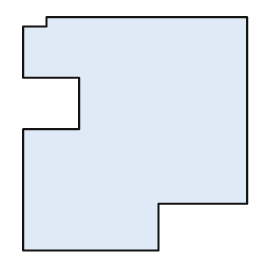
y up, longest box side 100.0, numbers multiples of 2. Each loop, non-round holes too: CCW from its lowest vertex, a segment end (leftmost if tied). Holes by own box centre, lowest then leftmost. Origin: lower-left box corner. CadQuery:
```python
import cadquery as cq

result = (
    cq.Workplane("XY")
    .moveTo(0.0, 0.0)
    .lineTo(58.0, 0.0)
    .lineTo(58.0, 20.0)
    .lineTo(96.0, 20.0)
    .lineTo(96.0, 100.0)
    .lineTo(10.0, 100.0)
    .lineTo(10.0, 96.0)
    .lineTo(0.0, 96.0)
    .lineTo(0.0, 74.0)
    .lineTo(24.0, 74.0)
    .lineTo(24.0, 52.0)
    .lineTo(0.0, 52.0)
    .close()
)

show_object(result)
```